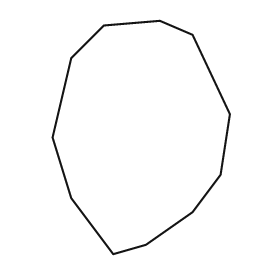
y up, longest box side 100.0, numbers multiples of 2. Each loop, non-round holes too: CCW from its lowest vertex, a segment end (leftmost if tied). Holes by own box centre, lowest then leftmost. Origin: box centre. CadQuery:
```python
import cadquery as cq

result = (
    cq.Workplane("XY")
    .moveTo(-12.0, -50.0)
    .lineTo(2.0, -46.0)
    .lineTo(22.0, -32.0)
    .lineTo(34.0, -16.0)
    .lineTo(38.0, 10.0)
    .lineTo(22.0, 44.0)
    .lineTo(8.0, 50.0)
    .lineTo(-16.0, 48.0)
    .lineTo(-30.0, 34.0)
    .lineTo(-38.0, 0.0)
    .lineTo(-30.0, -26.0)
    .close()
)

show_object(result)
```